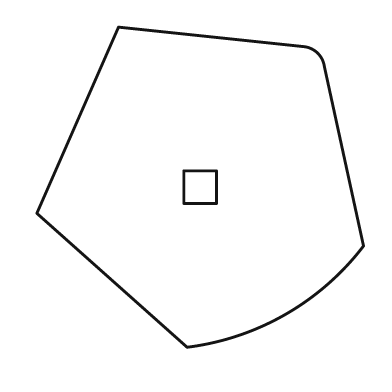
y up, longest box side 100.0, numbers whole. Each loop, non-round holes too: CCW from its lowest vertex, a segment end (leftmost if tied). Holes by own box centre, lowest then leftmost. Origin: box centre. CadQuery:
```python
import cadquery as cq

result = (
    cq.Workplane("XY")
    .moveTo(-4.0, -49.0)
    .threePointArc((26.0, -39.0), (50.0, -18.0))
    .lineTo(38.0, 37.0)
    .threePointArc((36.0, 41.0), (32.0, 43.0))
    .lineTo(-25.0, 49.0)
    .lineTo(-50.0, -8.0)
    .close()
    .moveTo(-5.0, -5.0)
    .lineTo(5.0, -5.0)
    .lineTo(5.0, 5.0)
    .lineTo(-5.0, 5.0)
    .close()
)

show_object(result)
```